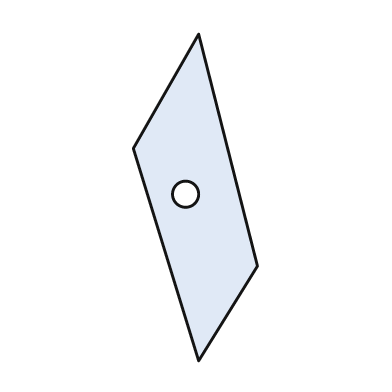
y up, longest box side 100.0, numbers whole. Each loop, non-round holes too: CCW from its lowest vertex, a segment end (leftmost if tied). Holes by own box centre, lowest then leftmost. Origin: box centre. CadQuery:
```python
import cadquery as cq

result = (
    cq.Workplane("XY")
    .moveTo(1.0, -50.0)
    .lineTo(19.0, -21.0)
    .lineTo(1.0, 50.0)
    .lineTo(-19.0, 15.0)
    .close()
    .moveTo(-3.0, 1.0)
    .circle(4.0)
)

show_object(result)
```